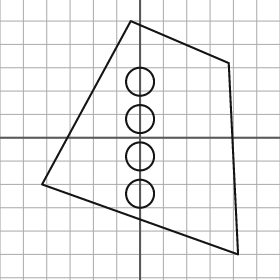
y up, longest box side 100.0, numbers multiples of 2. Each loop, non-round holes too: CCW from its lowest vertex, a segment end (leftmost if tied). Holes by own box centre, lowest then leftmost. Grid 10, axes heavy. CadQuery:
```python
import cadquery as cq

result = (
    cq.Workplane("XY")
    .moveTo(42.0, -50.0)
    .lineTo(38.0, 32.0)
    .lineTo(-4.0, 50.0)
    .lineTo(-42.0, -20.0)
    .close()
    .moveTo(0.0, -24.0)
    .circle(6.0)
    .moveTo(0.0, -8.0)
    .circle(6.0)
    .moveTo(0.0, 8.0)
    .circle(6.0)
    .moveTo(0.0, 24.0)
    .circle(6.0)
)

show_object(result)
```